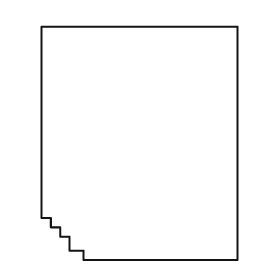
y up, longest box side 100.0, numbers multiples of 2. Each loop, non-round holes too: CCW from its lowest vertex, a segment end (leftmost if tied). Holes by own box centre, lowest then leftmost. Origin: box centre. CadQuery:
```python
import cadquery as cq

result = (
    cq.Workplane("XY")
    .moveTo(-24.0, -50.0)
    .lineTo(42.0, -50.0)
    .lineTo(42.0, 50.0)
    .lineTo(-42.0, 50.0)
    .lineTo(-42.0, -32.0)
    .lineTo(-38.0, -32.0)
    .lineTo(-38.0, -36.0)
    .lineTo(-34.0, -36.0)
    .lineTo(-34.0, -40.0)
    .lineTo(-30.0, -40.0)
    .lineTo(-30.0, -46.0)
    .lineTo(-24.0, -46.0)
    .close()
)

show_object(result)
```